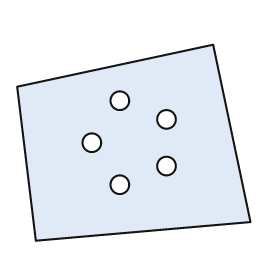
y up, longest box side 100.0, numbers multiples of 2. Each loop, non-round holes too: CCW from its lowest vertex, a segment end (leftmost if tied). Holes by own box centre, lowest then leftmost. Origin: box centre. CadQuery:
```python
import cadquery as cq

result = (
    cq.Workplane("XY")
    .moveTo(-42.0, -42.0)
    .lineTo(50.0, -34.0)
    .lineTo(34.0, 42.0)
    .lineTo(-50.0, 24.0)
    .close()
    .moveTo(-6.0, -18.0)
    .circle(4.0)
    .moveTo(14.0, -10.0)
    .circle(4.0)
    .moveTo(-18.0, 0.0)
    .circle(4.0)
    .moveTo(14.0, 10.0)
    .circle(4.0)
    .moveTo(-6.0, 18.0)
    .circle(4.0)
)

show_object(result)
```